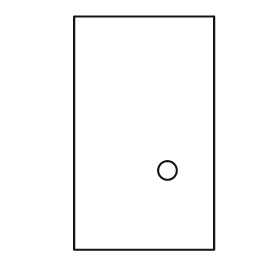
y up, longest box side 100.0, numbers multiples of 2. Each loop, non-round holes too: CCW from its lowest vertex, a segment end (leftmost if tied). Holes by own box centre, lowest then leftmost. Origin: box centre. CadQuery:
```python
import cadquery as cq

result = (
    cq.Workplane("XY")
    .moveTo(-30.0, -50.0)
    .lineTo(30.0, -50.0)
    .lineTo(30.0, 50.0)
    .lineTo(-30.0, 50.0)
    .close()
    .moveTo(10.0, -16.0)
    .circle(4.0)
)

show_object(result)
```